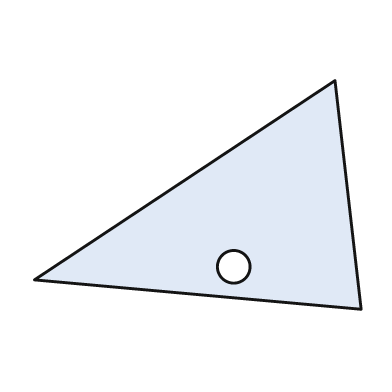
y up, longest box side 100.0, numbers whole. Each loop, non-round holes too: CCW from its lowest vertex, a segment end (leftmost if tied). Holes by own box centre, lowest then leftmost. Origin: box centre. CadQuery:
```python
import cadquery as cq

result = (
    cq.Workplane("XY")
    .moveTo(50.0, -35.0)
    .lineTo(42.0, 35.0)
    .lineTo(-50.0, -26.0)
    .close()
    .moveTo(11.0, -22.0)
    .circle(5.0)
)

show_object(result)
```